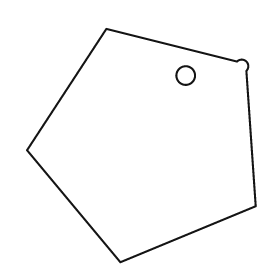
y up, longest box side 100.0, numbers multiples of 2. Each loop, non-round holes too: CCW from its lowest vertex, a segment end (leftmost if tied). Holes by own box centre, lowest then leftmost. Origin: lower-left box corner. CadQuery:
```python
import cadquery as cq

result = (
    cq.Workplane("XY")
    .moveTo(40.0, 0.0)
    .lineTo(98.0, 24.0)
    .lineTo(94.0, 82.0)
    .threePointArc((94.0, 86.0), (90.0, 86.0))
    .lineTo(34.0, 100.0)
    .lineTo(0.0, 48.0)
    .close()
    .moveTo(68.0, 80.0)
    .circle(4.0)
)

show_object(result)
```